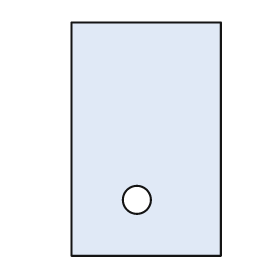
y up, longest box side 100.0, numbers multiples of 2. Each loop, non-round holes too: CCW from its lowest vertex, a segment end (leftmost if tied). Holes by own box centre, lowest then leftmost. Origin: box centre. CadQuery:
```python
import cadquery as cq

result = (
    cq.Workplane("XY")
    .moveTo(-32.0, -50.0)
    .lineTo(32.0, -50.0)
    .lineTo(32.0, 50.0)
    .lineTo(-32.0, 50.0)
    .close()
    .moveTo(-4.0, -26.0)
    .circle(6.0)
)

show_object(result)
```